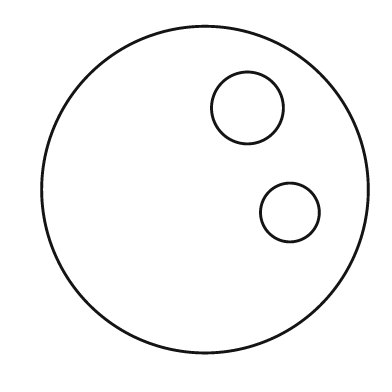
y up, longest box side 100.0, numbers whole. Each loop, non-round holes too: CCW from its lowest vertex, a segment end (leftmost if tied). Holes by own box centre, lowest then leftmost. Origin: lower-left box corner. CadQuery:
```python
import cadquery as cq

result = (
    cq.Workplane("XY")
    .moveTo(50.0, 50.0)
    .circle(50.0)
    .moveTo(76.0, 43.0)
    .circle(9.0)
    .moveTo(63.0, 75.0)
    .circle(11.0)
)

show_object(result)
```